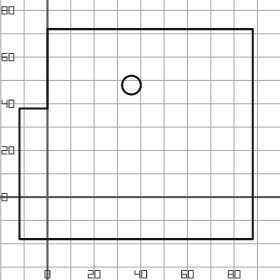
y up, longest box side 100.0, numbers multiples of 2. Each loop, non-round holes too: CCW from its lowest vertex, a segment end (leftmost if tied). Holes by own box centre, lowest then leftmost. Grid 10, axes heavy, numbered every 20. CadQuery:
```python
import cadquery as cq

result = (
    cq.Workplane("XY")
    .moveTo(-12.0, -18.0)
    .lineTo(88.0, -18.0)
    .lineTo(88.0, 72.0)
    .lineTo(0.0, 72.0)
    .lineTo(0.0, 38.0)
    .lineTo(-12.0, 38.0)
    .close()
    .moveTo(36.0, 48.0)
    .circle(4.0)
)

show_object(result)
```